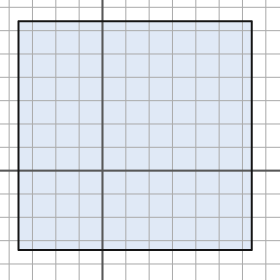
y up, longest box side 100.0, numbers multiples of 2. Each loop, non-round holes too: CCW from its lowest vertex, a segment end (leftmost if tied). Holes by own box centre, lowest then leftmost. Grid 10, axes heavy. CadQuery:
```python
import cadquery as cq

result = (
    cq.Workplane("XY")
    .moveTo(-36.0, -34.0)
    .lineTo(64.0, -34.0)
    .lineTo(64.0, 64.0)
    .lineTo(-36.0, 64.0)
    .close()
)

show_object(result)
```